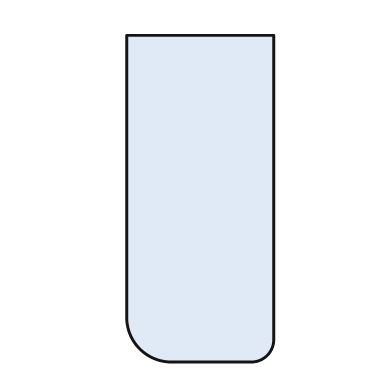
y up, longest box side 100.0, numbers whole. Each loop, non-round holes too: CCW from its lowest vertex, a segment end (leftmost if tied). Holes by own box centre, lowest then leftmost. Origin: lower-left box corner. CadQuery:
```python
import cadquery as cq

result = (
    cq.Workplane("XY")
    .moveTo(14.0, 0.0)
    .lineTo(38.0, 0.0)
    .threePointArc((43.0, 2.0), (45.0, 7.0))
    .lineTo(45.0, 100.0)
    .lineTo(0.0, 100.0)
    .lineTo(0.0, 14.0)
    .threePointArc((4.0, 4.0), (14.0, 0.0))
    .close()
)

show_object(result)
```